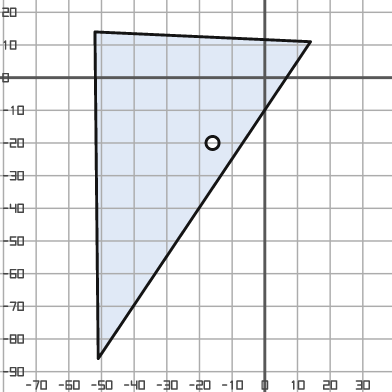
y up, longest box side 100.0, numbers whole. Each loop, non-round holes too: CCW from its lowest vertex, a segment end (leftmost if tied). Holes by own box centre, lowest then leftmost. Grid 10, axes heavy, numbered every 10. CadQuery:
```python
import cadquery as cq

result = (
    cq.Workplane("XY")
    .moveTo(-51.0, -86.0)
    .lineTo(14.0, 11.0)
    .lineTo(-52.0, 14.0)
    .close()
    .moveTo(-16.0, -20.0)
    .circle(2.0)
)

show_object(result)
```